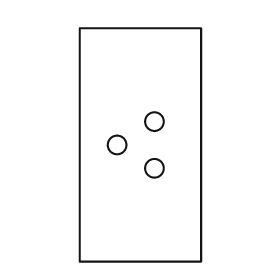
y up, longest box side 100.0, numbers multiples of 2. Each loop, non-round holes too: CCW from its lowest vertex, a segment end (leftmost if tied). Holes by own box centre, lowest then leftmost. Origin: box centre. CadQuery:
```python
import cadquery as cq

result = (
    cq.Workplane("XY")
    .moveTo(-26.0, -50.0)
    .lineTo(26.0, -50.0)
    .lineTo(26.0, 50.0)
    .lineTo(-26.0, 50.0)
    .close()
    .moveTo(6.0, -10.0)
    .circle(4.0)
    .moveTo(-10.0, 0.0)
    .circle(4.0)
    .moveTo(6.0, 10.0)
    .circle(4.0)
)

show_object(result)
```